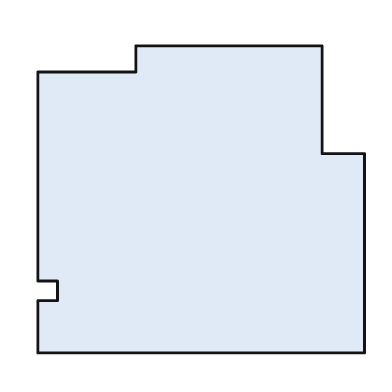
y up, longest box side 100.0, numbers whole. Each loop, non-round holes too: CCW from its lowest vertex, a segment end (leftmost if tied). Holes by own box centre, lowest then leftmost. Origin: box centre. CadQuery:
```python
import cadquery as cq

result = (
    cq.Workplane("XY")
    .moveTo(-50.0, -47.0)
    .lineTo(50.0, -47.0)
    .lineTo(50.0, 14.0)
    .lineTo(37.0, 14.0)
    .lineTo(37.0, 47.0)
    .lineTo(-20.0, 47.0)
    .lineTo(-20.0, 39.0)
    .lineTo(-50.0, 39.0)
    .lineTo(-50.0, -25.0)
    .lineTo(-44.0, -25.0)
    .lineTo(-44.0, -31.0)
    .lineTo(-50.0, -31.0)
    .close()
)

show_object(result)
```